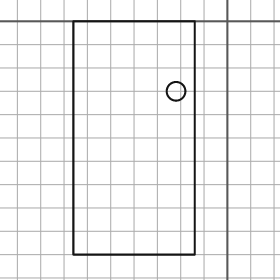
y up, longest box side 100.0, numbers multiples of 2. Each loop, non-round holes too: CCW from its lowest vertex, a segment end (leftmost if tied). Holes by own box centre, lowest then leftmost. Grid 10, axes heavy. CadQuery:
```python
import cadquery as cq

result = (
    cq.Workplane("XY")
    .moveTo(-66.0, -100.0)
    .lineTo(-14.0, -100.0)
    .lineTo(-14.0, 0.0)
    .lineTo(-66.0, 0.0)
    .close()
    .moveTo(-22.0, -30.0)
    .circle(4.0)
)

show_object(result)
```